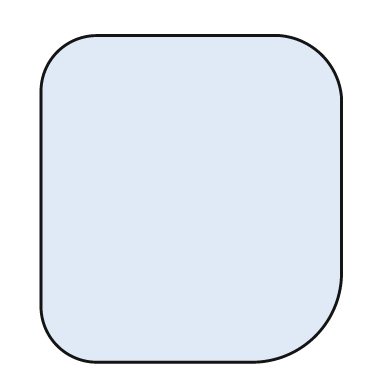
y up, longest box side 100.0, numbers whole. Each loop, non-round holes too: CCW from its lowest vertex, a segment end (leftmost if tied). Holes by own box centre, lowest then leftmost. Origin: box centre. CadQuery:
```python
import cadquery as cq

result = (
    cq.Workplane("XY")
    .moveTo(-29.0, -50.0)
    .lineTo(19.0, -50.0)
    .threePointArc((38.0, -42.0), (46.0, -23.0))
    .lineTo(46.0, 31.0)
    .threePointArc((40.0, 44.0), (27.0, 50.0))
    .lineTo(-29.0, 50.0)
    .threePointArc((-41.0, 45.0), (-46.0, 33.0))
    .lineTo(-46.0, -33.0)
    .threePointArc((-41.0, -45.0), (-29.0, -50.0))
    .close()
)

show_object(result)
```